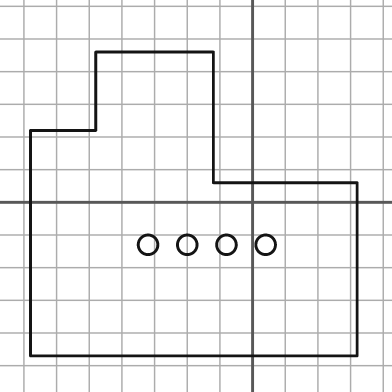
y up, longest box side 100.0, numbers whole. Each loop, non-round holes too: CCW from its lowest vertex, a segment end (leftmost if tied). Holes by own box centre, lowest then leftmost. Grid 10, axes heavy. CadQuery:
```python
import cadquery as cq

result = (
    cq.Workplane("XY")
    .moveTo(-68.0, -47.0)
    .lineTo(32.0, -47.0)
    .lineTo(32.0, 6.0)
    .lineTo(-12.0, 6.0)
    .lineTo(-12.0, 46.0)
    .lineTo(-48.0, 46.0)
    .lineTo(-48.0, 22.0)
    .lineTo(-68.0, 22.0)
    .close()
    .moveTo(-32.0, -13.0)
    .circle(3.0)
    .moveTo(-20.0, -13.0)
    .circle(3.0)
    .moveTo(-8.0, -13.0)
    .circle(3.0)
    .moveTo(4.0, -13.0)
    .circle(3.0)
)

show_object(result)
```